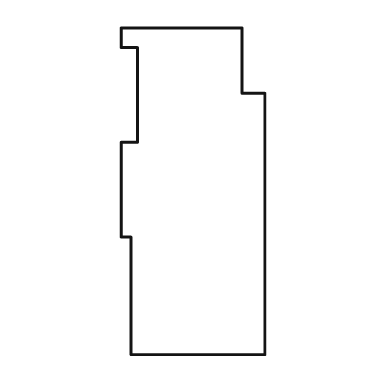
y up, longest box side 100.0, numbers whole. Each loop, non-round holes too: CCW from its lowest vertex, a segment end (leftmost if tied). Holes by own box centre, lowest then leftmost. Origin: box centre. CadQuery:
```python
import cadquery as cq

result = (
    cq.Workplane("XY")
    .moveTo(-19.0, -50.0)
    .lineTo(22.0, -50.0)
    .lineTo(22.0, 30.0)
    .lineTo(15.0, 30.0)
    .lineTo(15.0, 50.0)
    .lineTo(-22.0, 50.0)
    .lineTo(-22.0, 44.0)
    .lineTo(-17.0, 44.0)
    .lineTo(-17.0, 15.0)
    .lineTo(-22.0, 15.0)
    .lineTo(-22.0, -14.0)
    .lineTo(-19.0, -14.0)
    .close()
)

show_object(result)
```